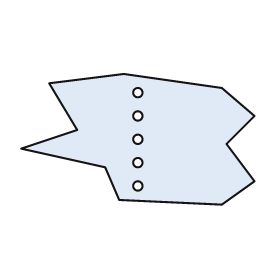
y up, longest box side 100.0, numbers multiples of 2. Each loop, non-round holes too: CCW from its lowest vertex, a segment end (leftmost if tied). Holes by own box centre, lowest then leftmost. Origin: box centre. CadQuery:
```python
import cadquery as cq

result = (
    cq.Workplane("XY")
    .moveTo(36.0, -28.0)
    .lineTo(50.0, -18.0)
    .lineTo(38.0, -2.0)
    .lineTo(50.0, 10.0)
    .lineTo(36.0, 22.0)
    .lineTo(-6.0, 28.0)
    .lineTo(-38.0, 24.0)
    .lineTo(-26.0, 4.0)
    .lineTo(-50.0, -4.0)
    .lineTo(-14.0, -12.0)
    .lineTo(-8.0, -26.0)
    .close()
    .moveTo(0.0, -20.0)
    .circle(2.0)
    .moveTo(0.0, -10.0)
    .circle(2.0)
    .moveTo(0.0, 0.0)
    .circle(2.0)
    .moveTo(0.0, 10.0)
    .circle(2.0)
    .moveTo(0.0, 20.0)
    .circle(2.0)
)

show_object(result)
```